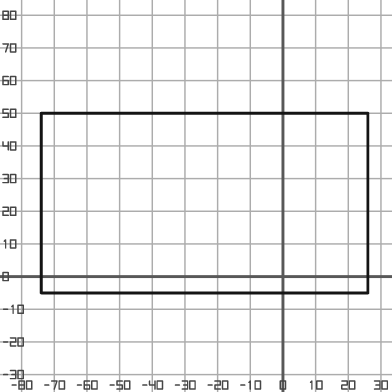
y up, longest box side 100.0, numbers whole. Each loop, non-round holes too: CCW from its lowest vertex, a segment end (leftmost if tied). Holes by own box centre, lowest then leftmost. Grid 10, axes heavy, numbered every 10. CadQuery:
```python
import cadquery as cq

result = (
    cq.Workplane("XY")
    .moveTo(-74.0, -5.0)
    .lineTo(26.0, -5.0)
    .lineTo(26.0, 50.0)
    .lineTo(-74.0, 50.0)
    .close()
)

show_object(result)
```